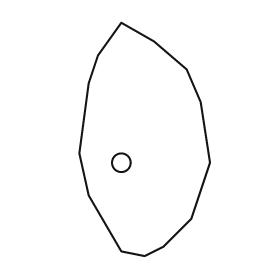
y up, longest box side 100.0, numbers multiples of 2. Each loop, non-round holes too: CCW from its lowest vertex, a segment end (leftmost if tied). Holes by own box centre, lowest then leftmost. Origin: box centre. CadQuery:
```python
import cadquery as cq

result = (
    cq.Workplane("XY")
    .moveTo(0.0, -50.0)
    .lineTo(8.0, -46.0)
    .lineTo(20.0, -34.0)
    .lineTo(28.0, -10.0)
    .lineTo(24.0, 16.0)
    .lineTo(18.0, 30.0)
    .lineTo(4.0, 42.0)
    .lineTo(-10.0, 50.0)
    .lineTo(-20.0, 36.0)
    .lineTo(-24.0, 24.0)
    .lineTo(-28.0, -6.0)
    .lineTo(-24.0, -24.0)
    .lineTo(-10.0, -48.0)
    .close()
    .moveTo(-10.0, -10.0)
    .circle(4.0)
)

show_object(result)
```